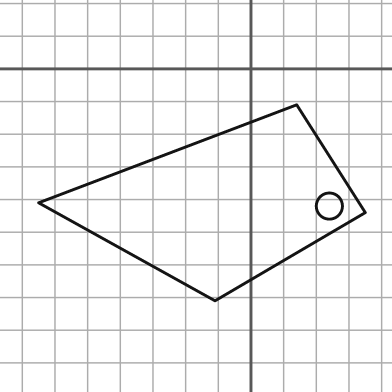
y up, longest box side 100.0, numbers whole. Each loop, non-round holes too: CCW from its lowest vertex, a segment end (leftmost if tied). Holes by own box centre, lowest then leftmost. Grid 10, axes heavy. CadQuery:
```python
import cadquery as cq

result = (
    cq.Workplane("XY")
    .moveTo(-11.0, -71.0)
    .lineTo(35.0, -44.0)
    .lineTo(14.0, -11.0)
    .lineTo(-65.0, -41.0)
    .close()
    .moveTo(24.0, -42.0)
    .circle(4.0)
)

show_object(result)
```